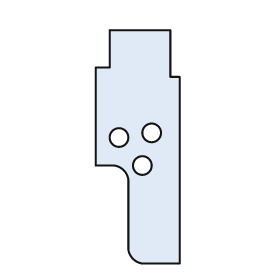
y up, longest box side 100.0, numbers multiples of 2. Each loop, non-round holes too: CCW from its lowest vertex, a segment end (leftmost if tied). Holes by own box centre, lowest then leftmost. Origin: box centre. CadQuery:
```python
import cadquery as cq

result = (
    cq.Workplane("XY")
    .moveTo(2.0, -50.0)
    .lineTo(18.0, -50.0)
    .lineTo(18.0, 30.0)
    .lineTo(14.0, 30.0)
    .lineTo(14.0, 50.0)
    .lineTo(-12.0, 50.0)
    .lineTo(-12.0, 34.0)
    .lineTo(-18.0, 34.0)
    .lineTo(-18.0, -8.0)
    .lineTo(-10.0, -8.0)
    .threePointArc((-6.0, -10.0), (-4.0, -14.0))
    .lineTo(-4.0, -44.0)
    .threePointArc((-2.0, -48.0), (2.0, -50.0))
    .close()
    .moveTo(2.0, -8.0)
    .circle(4.0)
    .moveTo(-8.0, 4.0)
    .circle(4.0)
    .moveTo(6.0, 6.0)
    .circle(4.0)
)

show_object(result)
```